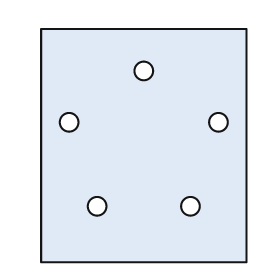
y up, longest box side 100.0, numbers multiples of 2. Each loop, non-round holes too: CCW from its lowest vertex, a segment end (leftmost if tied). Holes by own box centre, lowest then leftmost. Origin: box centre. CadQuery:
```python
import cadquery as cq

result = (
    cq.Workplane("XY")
    .moveTo(-44.0, -50.0)
    .lineTo(44.0, -50.0)
    .lineTo(44.0, 50.0)
    .lineTo(-44.0, 50.0)
    .close()
    .moveTo(-20.0, -26.0)
    .circle(4.0)
    .moveTo(20.0, -26.0)
    .circle(4.0)
    .moveTo(-32.0, 10.0)
    .circle(4.0)
    .moveTo(32.0, 10.0)
    .circle(4.0)
    .moveTo(0.0, 32.0)
    .circle(4.0)
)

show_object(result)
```